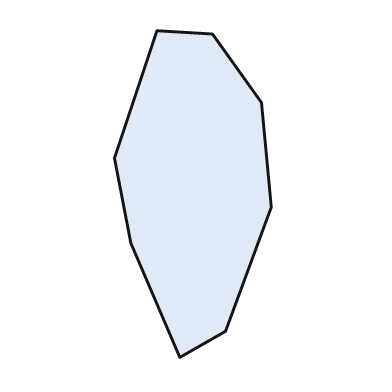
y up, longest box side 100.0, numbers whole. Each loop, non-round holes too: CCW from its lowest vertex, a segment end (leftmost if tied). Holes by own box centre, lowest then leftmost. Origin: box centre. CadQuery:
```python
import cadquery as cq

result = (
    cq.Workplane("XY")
    .moveTo(-4.0, -50.0)
    .lineTo(10.0, -42.0)
    .lineTo(24.0, -4.0)
    .lineTo(21.0, 28.0)
    .lineTo(6.0, 49.0)
    .lineTo(-11.0, 50.0)
    .lineTo(-24.0, 11.0)
    .lineTo(-19.0, -15.0)
    .close()
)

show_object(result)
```